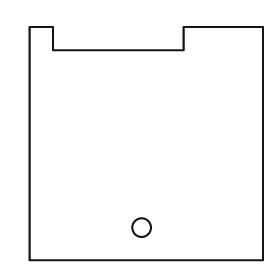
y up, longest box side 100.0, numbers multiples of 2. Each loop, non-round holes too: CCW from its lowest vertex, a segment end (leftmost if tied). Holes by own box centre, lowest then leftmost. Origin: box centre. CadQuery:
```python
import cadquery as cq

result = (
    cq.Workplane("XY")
    .moveTo(-50.0, -50.0)
    .lineTo(50.0, -50.0)
    .lineTo(50.0, 50.0)
    .lineTo(16.0, 50.0)
    .lineTo(16.0, 40.0)
    .lineTo(-40.0, 40.0)
    .lineTo(-40.0, 50.0)
    .lineTo(-50.0, 50.0)
    .close()
    .moveTo(-2.0, -36.0)
    .circle(4.0)
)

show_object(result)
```